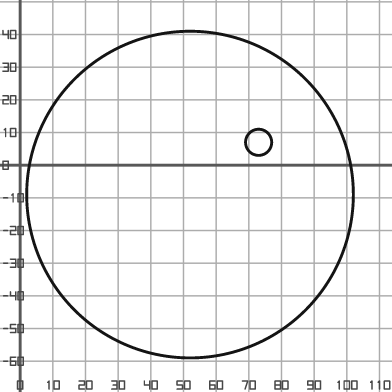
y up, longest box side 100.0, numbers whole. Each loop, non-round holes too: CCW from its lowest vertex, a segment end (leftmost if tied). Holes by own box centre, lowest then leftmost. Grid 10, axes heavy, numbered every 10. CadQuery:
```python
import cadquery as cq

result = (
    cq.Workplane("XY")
    .moveTo(52.0, -9.0)
    .circle(50.0)
    .moveTo(73.0, 7.0)
    .circle(4.0)
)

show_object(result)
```